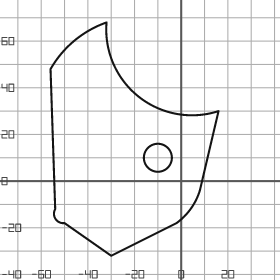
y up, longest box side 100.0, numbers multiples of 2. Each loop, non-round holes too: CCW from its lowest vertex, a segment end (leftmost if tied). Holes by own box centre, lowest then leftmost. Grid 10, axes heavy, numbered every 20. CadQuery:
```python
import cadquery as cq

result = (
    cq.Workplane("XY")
    .moveTo(-30.0, -32.0)
    .lineTo(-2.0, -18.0)
    .threePointArc((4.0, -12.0), (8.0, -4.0))
    .lineTo(16.0, 30.0)
    .threePointArc((-18.0, 36.0), (-32.0, 68.0))
    .threePointArc((-46.0, 60.0), (-56.0, 48.0))
    .lineTo(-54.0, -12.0)
    .threePointArc((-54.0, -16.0), (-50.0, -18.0))
    .close()
    .moveTo(-10.0, 10.0)
    .circle(6.0)
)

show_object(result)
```